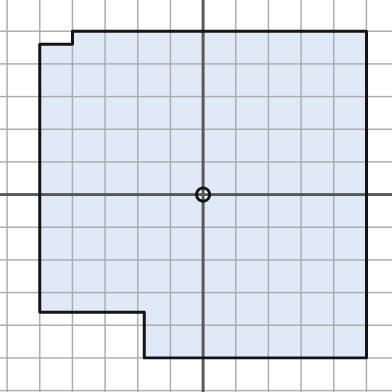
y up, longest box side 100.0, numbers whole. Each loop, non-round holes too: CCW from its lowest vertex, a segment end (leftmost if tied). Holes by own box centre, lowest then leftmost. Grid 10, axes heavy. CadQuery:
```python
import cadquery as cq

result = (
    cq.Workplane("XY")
    .moveTo(-18.0, -50.0)
    .lineTo(50.0, -50.0)
    .lineTo(50.0, 50.0)
    .lineTo(-40.0, 50.0)
    .lineTo(-40.0, 46.0)
    .lineTo(-50.0, 46.0)
    .lineTo(-50.0, -36.0)
    .lineTo(-18.0, -36.0)
    .close()
    .moveTo(0.0, 0.0)
    .circle(2.0)
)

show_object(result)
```